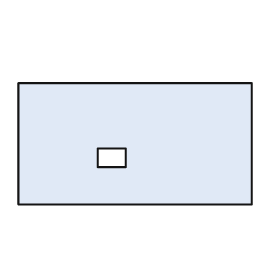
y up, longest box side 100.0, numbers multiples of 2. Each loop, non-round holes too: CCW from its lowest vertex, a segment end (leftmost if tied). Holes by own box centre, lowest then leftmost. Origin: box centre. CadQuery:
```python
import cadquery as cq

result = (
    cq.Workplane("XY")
    .moveTo(-50.0, -26.0)
    .lineTo(50.0, -26.0)
    .lineTo(50.0, 26.0)
    .lineTo(-50.0, 26.0)
    .close()
    .moveTo(-16.0, -10.0)
    .lineTo(-4.0, -10.0)
    .lineTo(-4.0, -2.0)
    .lineTo(-16.0, -2.0)
    .close()
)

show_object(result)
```